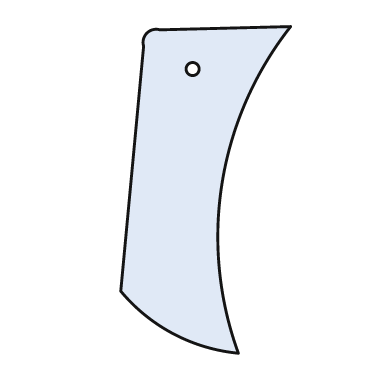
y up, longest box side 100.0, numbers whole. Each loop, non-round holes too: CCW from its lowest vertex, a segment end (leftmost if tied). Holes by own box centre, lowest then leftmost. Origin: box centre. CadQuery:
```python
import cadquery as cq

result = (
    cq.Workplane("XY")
    .moveTo(10.0, -50.0)
    .threePointArc((5.0, 2.0), (26.0, 50.0))
    .lineTo(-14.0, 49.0)
    .threePointArc((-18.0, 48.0), (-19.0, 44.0))
    .lineTo(-26.0, -31.0)
    .threePointArc((-10.0, -44.0), (10.0, -50.0))
    .close()
    .moveTo(-4.0, 37.0)
    .circle(2.0)
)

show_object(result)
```